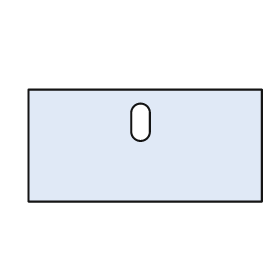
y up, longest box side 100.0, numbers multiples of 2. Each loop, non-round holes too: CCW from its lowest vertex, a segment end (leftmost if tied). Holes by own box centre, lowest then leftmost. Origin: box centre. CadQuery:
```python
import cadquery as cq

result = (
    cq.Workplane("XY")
    .moveTo(-50.0, -24.0)
    .lineTo(50.0, -24.0)
    .lineTo(50.0, 24.0)
    .lineTo(-50.0, 24.0)
    .close()
    .moveTo(-6.0, 6.0)
    .threePointArc((-2.0, 2.0), (2.0, 6.0))
    .lineTo(2.0, 14.0)
    .threePointArc((-2.0, 18.0), (-6.0, 14.0))
    .close()
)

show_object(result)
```